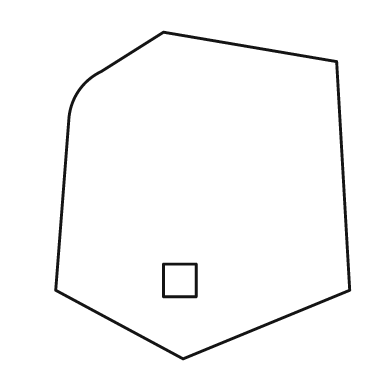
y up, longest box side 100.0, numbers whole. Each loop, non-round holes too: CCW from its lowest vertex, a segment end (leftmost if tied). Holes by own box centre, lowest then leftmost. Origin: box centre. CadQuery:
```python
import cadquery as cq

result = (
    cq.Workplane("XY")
    .moveTo(-6.0, -50.0)
    .lineTo(45.0, -29.0)
    .lineTo(41.0, 41.0)
    .lineTo(-12.0, 50.0)
    .lineTo(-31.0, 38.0)
    .threePointArc((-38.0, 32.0), (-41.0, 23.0))
    .lineTo(-45.0, -29.0)
    .close()
    .moveTo(-12.0, -31.0)
    .lineTo(-2.0, -31.0)
    .lineTo(-2.0, -21.0)
    .lineTo(-12.0, -21.0)
    .close()
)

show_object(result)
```